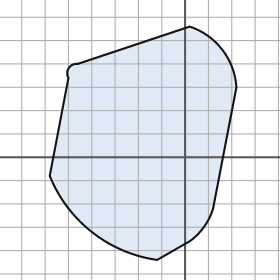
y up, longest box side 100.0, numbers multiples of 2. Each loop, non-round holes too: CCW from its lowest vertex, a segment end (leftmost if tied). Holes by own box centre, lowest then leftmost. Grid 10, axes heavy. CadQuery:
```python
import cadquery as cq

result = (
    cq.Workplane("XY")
    .moveTo(-12.0, -44.0)
    .lineTo(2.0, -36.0)
    .threePointArc((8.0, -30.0), (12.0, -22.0))
    .lineTo(22.0, 30.0)
    .threePointArc((16.0, 46.0), (2.0, 56.0))
    .lineTo(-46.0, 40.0)
    .threePointArc((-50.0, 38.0), (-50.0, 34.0))
    .lineTo(-58.0, -8.0)
    .threePointArc((-40.0, -32.0), (-12.0, -44.0))
    .close()
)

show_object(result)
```